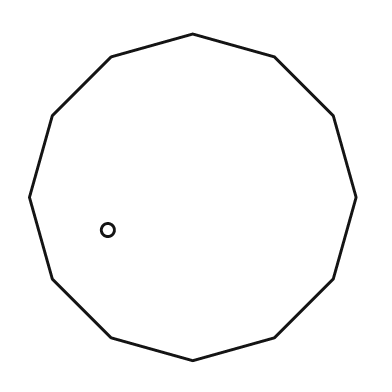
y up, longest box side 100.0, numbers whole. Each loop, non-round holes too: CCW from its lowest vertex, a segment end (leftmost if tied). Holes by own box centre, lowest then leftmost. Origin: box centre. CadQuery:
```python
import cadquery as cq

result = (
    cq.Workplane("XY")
    .moveTo(0.0, -50.0)
    .lineTo(25.0, -43.0)
    .lineTo(43.0, -25.0)
    .lineTo(50.0, 0.0)
    .lineTo(43.0, 25.0)
    .lineTo(25.0, 43.0)
    .lineTo(0.0, 50.0)
    .lineTo(-25.0, 43.0)
    .lineTo(-43.0, 25.0)
    .lineTo(-50.0, 0.0)
    .lineTo(-43.0, -25.0)
    .lineTo(-25.0, -43.0)
    .close()
    .moveTo(-26.0, -10.0)
    .circle(2.0)
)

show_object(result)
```